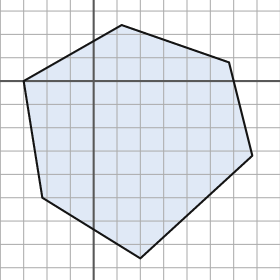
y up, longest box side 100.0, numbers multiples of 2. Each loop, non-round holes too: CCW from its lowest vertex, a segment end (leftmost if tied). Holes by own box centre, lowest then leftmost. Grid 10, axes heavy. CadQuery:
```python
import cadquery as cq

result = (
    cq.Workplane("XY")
    .moveTo(20.0, -76.0)
    .lineTo(68.0, -32.0)
    .lineTo(58.0, 8.0)
    .lineTo(12.0, 24.0)
    .lineTo(-30.0, 0.0)
    .lineTo(-22.0, -50.0)
    .close()
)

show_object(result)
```